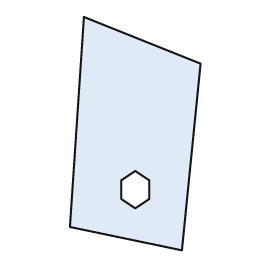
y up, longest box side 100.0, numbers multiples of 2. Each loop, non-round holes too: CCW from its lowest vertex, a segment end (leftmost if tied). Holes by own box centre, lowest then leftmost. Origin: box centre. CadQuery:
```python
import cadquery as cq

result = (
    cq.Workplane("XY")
    .moveTo(20.0, -50.0)
    .lineTo(28.0, 30.0)
    .lineTo(-22.0, 50.0)
    .lineTo(-28.0, -40.0)
    .close()
    .moveTo(0.0, -32.0)
    .lineTo(6.0, -28.0)
    .lineTo(6.0, -20.0)
    .lineTo(0.0, -16.0)
    .lineTo(-6.0, -20.0)
    .lineTo(-6.0, -28.0)
    .close()
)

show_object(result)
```